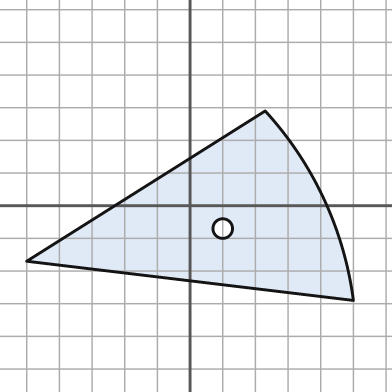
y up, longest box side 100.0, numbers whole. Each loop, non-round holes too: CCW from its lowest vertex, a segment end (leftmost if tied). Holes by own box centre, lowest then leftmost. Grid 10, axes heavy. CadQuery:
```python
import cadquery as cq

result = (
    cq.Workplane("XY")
    .moveTo(50.0, -29.0)
    .threePointArc((41.0, 2.0), (23.0, 29.0))
    .lineTo(-50.0, -17.0)
    .close()
    .moveTo(10.0, -7.0)
    .circle(3.0)
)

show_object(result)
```